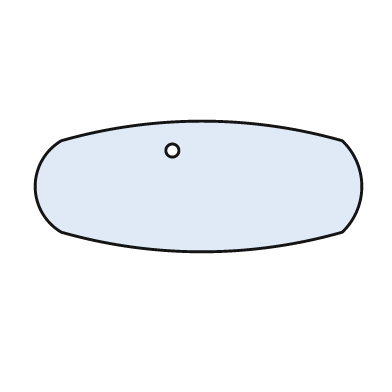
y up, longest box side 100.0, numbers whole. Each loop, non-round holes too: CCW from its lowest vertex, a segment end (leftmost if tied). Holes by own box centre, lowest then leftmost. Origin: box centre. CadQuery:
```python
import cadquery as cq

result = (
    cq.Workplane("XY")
    .moveTo(-42.0, -14.0)
    .threePointArc((1.0, -20.0), (44.0, -14.0))
    .threePointArc((50.0, 0.0), (44.0, 14.0))
    .threePointArc((1.0, 20.0), (-42.0, 14.0))
    .threePointArc((-50.0, 0.0), (-42.0, -14.0))
    .close()
    .moveTo(-8.0, 11.0)
    .circle(2.0)
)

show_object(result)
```